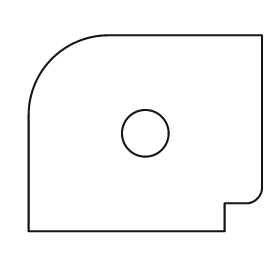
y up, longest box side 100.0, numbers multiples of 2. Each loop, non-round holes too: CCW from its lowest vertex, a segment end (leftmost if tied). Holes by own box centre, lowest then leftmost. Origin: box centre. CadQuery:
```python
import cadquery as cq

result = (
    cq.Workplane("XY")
    .moveTo(-50.0, -42.0)
    .lineTo(34.0, -42.0)
    .lineTo(34.0, -30.0)
    .lineTo(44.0, -30.0)
    .threePointArc((48.0, -28.0), (50.0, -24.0))
    .lineTo(50.0, 42.0)
    .lineTo(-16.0, 42.0)
    .threePointArc((-40.0, 32.0), (-50.0, 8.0))
    .close()
    .moveTo(0.0, 0.0)
    .circle(10.0)
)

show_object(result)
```